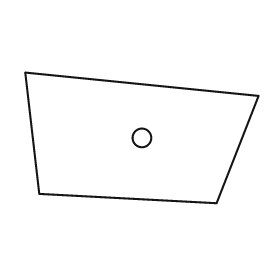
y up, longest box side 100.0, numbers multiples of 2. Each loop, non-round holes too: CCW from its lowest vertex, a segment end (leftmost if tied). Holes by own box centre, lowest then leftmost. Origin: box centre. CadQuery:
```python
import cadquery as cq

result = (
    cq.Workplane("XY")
    .moveTo(32.0, -28.0)
    .lineTo(50.0, 18.0)
    .lineTo(-50.0, 28.0)
    .lineTo(-44.0, -24.0)
    .close()
    .moveTo(0.0, 0.0)
    .circle(4.0)
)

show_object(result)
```